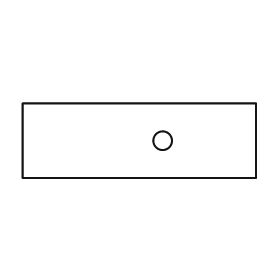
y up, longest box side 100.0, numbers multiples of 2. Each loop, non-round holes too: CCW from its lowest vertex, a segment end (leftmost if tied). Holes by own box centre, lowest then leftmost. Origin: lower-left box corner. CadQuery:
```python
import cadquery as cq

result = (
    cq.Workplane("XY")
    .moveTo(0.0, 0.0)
    .lineTo(100.0, 0.0)
    .lineTo(100.0, 32.0)
    .lineTo(0.0, 32.0)
    .close()
    .moveTo(60.0, 16.0)
    .circle(4.0)
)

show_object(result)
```